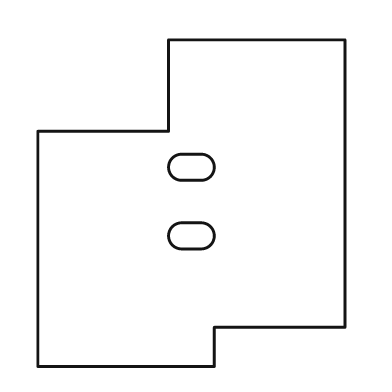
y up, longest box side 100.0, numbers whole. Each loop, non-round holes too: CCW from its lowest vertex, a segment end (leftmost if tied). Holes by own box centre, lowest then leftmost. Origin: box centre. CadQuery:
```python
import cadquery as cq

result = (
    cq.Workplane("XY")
    .moveTo(-47.0, -50.0)
    .lineTo(7.0, -50.0)
    .lineTo(7.0, -38.0)
    .lineTo(47.0, -38.0)
    .lineTo(47.0, 50.0)
    .lineTo(-7.0, 50.0)
    .lineTo(-7.0, 22.0)
    .lineTo(-47.0, 22.0)
    .close()
    .moveTo(-3.0, -14.0)
    .lineTo(3.0, -14.0)
    .threePointArc((7.0, -10.0), (3.0, -6.0))
    .lineTo(-3.0, -6.0)
    .threePointArc((-7.0, -10.0), (-3.0, -14.0))
    .close()
    .moveTo(-3.0, 7.0)
    .lineTo(3.0, 7.0)
    .threePointArc((7.0, 11.0), (3.0, 15.0))
    .lineTo(-3.0, 15.0)
    .threePointArc((-7.0, 11.0), (-3.0, 7.0))
    .close()
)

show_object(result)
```